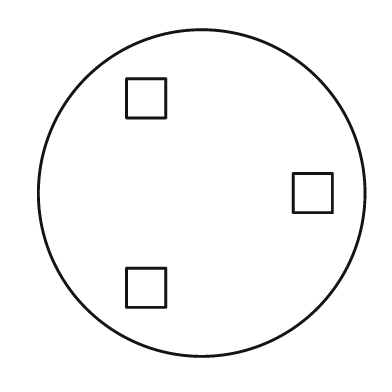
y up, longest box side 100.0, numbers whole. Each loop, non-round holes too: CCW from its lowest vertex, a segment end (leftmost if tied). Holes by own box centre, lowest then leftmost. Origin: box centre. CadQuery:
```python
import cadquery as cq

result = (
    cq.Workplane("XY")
    .moveTo(0.0, 0.0)
    .circle(50.0)
    .moveTo(-23.0, -35.0)
    .lineTo(-11.0, -35.0)
    .lineTo(-11.0, -23.0)
    .lineTo(-23.0, -23.0)
    .close()
    .moveTo(28.0, -6.0)
    .lineTo(40.0, -6.0)
    .lineTo(40.0, 6.0)
    .lineTo(28.0, 6.0)
    .close()
    .moveTo(-23.0, 23.0)
    .lineTo(-11.0, 23.0)
    .lineTo(-11.0, 35.0)
    .lineTo(-23.0, 35.0)
    .close()
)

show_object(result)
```